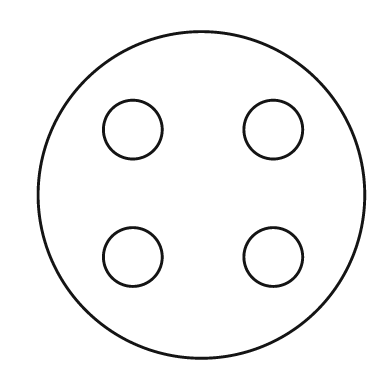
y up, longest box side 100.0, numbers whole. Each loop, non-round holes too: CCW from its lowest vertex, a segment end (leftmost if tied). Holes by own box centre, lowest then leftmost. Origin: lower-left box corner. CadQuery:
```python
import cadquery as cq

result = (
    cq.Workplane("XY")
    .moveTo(50.0, 50.0)
    .circle(50.0)
    .moveTo(29.0, 31.0)
    .circle(9.0)
    .moveTo(72.0, 31.0)
    .circle(9.0)
    .moveTo(29.0, 70.0)
    .circle(9.0)
    .moveTo(72.0, 70.0)
    .circle(9.0)
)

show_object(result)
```